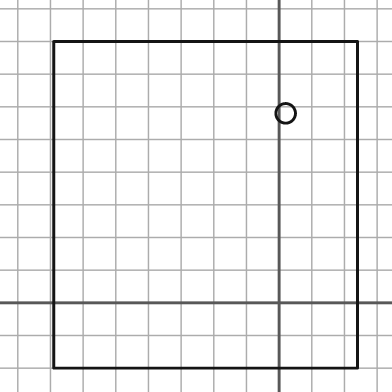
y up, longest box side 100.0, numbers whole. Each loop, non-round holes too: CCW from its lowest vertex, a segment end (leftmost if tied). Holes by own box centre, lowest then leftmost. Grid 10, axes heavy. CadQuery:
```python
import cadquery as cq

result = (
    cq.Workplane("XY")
    .moveTo(-69.0, -20.0)
    .lineTo(24.0, -20.0)
    .lineTo(24.0, 80.0)
    .lineTo(-69.0, 80.0)
    .close()
    .moveTo(2.0, 58.0)
    .circle(3.0)
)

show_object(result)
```